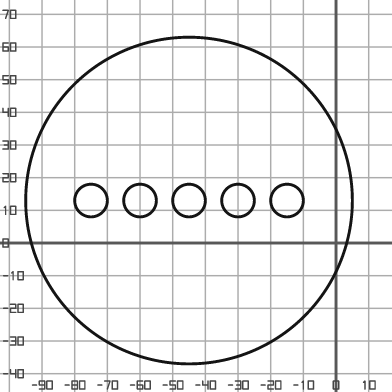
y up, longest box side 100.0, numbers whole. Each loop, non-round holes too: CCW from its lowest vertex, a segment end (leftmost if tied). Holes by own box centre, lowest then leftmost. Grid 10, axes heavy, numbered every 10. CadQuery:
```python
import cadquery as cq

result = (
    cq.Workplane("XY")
    .moveTo(-45.0, 13.0)
    .circle(50.0)
    .moveTo(-75.0, 13.0)
    .circle(5.0)
    .moveTo(-60.0, 13.0)
    .circle(5.0)
    .moveTo(-45.0, 13.0)
    .circle(5.0)
    .moveTo(-30.0, 13.0)
    .circle(5.0)
    .moveTo(-15.0, 13.0)
    .circle(5.0)
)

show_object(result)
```